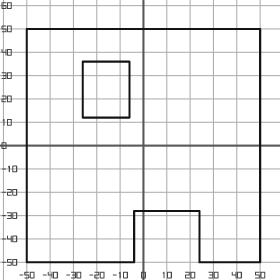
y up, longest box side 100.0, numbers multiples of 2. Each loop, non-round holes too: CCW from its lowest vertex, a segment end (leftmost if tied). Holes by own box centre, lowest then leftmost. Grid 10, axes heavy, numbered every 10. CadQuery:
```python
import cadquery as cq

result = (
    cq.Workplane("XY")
    .moveTo(-50.0, -50.0)
    .lineTo(-4.0, -50.0)
    .lineTo(-4.0, -28.0)
    .lineTo(24.0, -28.0)
    .lineTo(24.0, -50.0)
    .lineTo(50.0, -50.0)
    .lineTo(50.0, 50.0)
    .lineTo(-50.0, 50.0)
    .close()
    .moveTo(-26.0, 12.0)
    .lineTo(-6.0, 12.0)
    .lineTo(-6.0, 36.0)
    .lineTo(-26.0, 36.0)
    .close()
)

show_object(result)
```